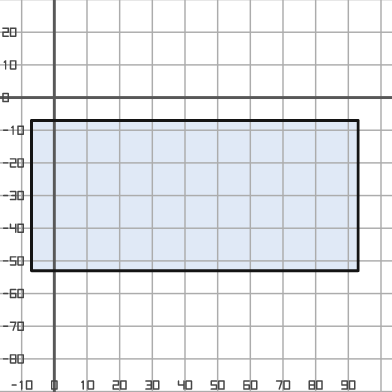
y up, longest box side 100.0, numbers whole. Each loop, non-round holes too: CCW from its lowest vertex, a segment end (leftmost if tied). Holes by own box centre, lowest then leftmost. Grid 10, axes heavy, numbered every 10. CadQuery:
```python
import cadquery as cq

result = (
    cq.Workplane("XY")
    .moveTo(-7.0, -53.0)
    .lineTo(93.0, -53.0)
    .lineTo(93.0, -7.0)
    .lineTo(-7.0, -7.0)
    .close()
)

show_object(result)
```